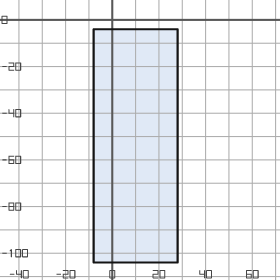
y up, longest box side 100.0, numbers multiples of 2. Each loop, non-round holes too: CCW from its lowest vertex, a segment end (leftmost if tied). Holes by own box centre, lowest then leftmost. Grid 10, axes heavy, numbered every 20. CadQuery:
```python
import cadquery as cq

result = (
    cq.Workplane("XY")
    .moveTo(-8.0, -104.0)
    .lineTo(28.0, -104.0)
    .lineTo(28.0, -4.0)
    .lineTo(-8.0, -4.0)
    .close()
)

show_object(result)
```